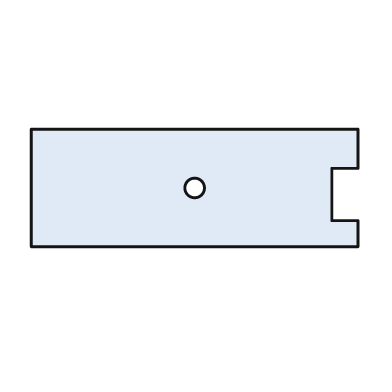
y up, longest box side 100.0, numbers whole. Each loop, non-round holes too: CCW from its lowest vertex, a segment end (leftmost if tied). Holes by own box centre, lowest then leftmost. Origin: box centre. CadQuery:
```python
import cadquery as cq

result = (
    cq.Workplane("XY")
    .moveTo(-50.0, -18.0)
    .lineTo(50.0, -18.0)
    .lineTo(50.0, -10.0)
    .lineTo(42.0, -10.0)
    .lineTo(42.0, 6.0)
    .lineTo(50.0, 6.0)
    .lineTo(50.0, 18.0)
    .lineTo(-50.0, 18.0)
    .close()
    .moveTo(0.0, 0.0)
    .circle(3.0)
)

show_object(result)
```